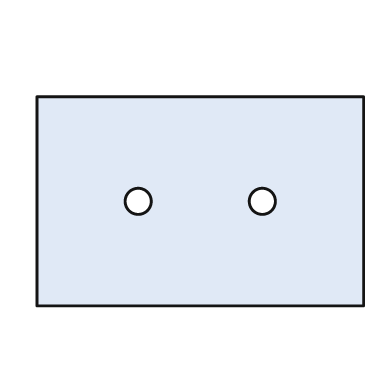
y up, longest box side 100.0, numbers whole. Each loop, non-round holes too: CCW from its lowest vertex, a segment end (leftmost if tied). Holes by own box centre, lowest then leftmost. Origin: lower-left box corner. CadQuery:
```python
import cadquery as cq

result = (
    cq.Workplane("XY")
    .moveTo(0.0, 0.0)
    .lineTo(100.0, 0.0)
    .lineTo(100.0, 64.0)
    .lineTo(0.0, 64.0)
    .close()
    .moveTo(31.0, 32.0)
    .circle(4.0)
    .moveTo(69.0, 32.0)
    .circle(4.0)
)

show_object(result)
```